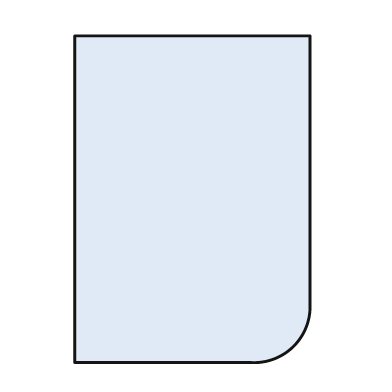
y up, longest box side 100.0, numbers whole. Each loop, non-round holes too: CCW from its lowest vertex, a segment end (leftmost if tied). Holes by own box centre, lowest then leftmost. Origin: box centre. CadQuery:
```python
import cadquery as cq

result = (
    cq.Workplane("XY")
    .moveTo(-36.0, -50.0)
    .lineTo(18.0, -50.0)
    .threePointArc((31.0, -45.0), (36.0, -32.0))
    .lineTo(36.0, 50.0)
    .lineTo(-36.0, 50.0)
    .close()
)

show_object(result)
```